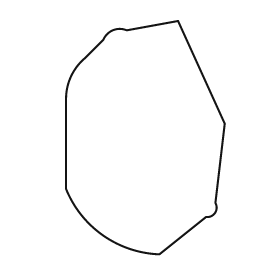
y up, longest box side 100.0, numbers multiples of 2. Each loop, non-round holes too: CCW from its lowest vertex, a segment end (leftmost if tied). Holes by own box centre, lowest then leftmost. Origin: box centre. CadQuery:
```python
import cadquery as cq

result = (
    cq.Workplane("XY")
    .moveTo(6.0, -50.0)
    .lineTo(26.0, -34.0)
    .threePointArc((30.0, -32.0), (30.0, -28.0))
    .lineTo(34.0, 6.0)
    .lineTo(14.0, 50.0)
    .lineTo(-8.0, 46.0)
    .threePointArc((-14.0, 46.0), (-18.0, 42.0))
    .lineTo(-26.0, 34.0)
    .threePointArc((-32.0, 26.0), (-34.0, 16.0))
    .lineTo(-34.0, -22.0)
    .threePointArc((-18.0, -42.0), (6.0, -50.0))
    .close()
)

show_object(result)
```